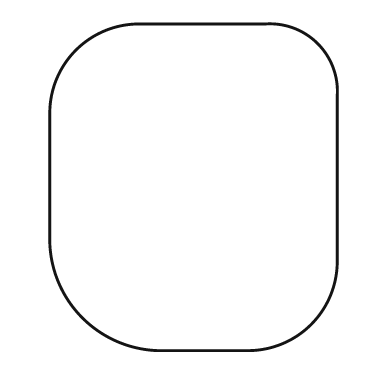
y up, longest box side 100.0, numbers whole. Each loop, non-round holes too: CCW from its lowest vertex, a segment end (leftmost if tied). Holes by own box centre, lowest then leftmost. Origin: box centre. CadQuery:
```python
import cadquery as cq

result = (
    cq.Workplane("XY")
    .moveTo(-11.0, -50.0)
    .lineTo(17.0, -50.0)
    .threePointArc((36.0, -42.0), (44.0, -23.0))
    .lineTo(44.0, 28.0)
    .threePointArc((38.0, 44.0), (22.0, 50.0))
    .lineTo(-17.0, 50.0)
    .threePointArc((-36.0, 42.0), (-44.0, 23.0))
    .lineTo(-44.0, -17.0)
    .threePointArc((-34.0, -40.0), (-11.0, -50.0))
    .close()
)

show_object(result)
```